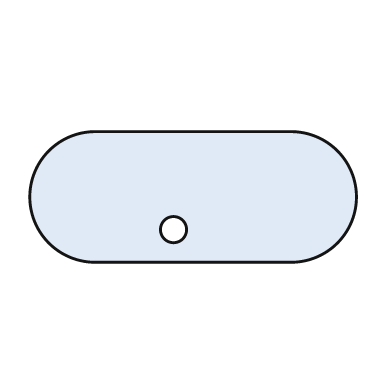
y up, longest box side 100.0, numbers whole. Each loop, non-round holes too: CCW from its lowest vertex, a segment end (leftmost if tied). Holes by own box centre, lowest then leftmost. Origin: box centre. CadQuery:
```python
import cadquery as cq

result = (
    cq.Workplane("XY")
    .moveTo(-30.0, -20.0)
    .lineTo(30.0, -20.0)
    .threePointArc((50.0, 0.0), (30.0, 20.0))
    .lineTo(-30.0, 20.0)
    .threePointArc((-50.0, 0.0), (-30.0, -20.0))
    .close()
    .moveTo(-6.0, -10.0)
    .circle(4.0)
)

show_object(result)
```